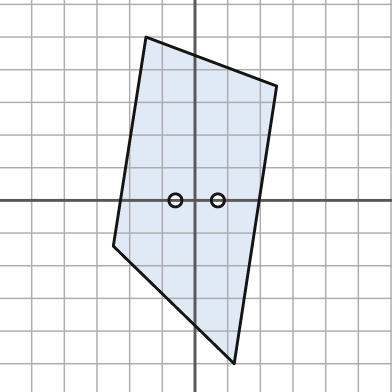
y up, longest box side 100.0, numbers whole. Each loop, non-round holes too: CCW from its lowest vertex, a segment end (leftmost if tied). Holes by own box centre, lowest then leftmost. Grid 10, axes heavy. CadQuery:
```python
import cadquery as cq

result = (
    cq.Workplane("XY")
    .moveTo(12.0, -50.0)
    .lineTo(25.0, 35.0)
    .lineTo(-15.0, 50.0)
    .lineTo(-25.0, -14.0)
    .close()
    .moveTo(-6.0, 0.0)
    .circle(2.0)
    .moveTo(7.0, 0.0)
    .circle(2.0)
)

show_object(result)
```